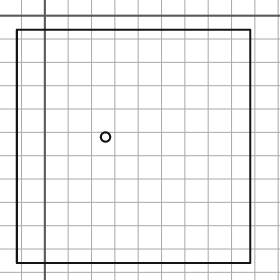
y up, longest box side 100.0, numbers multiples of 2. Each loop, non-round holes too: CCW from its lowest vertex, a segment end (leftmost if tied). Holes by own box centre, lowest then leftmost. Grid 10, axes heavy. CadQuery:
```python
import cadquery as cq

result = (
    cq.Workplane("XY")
    .moveTo(-12.0, -106.0)
    .lineTo(88.0, -106.0)
    .lineTo(88.0, -6.0)
    .lineTo(-12.0, -6.0)
    .close()
    .moveTo(26.0, -52.0)
    .circle(2.0)
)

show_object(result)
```